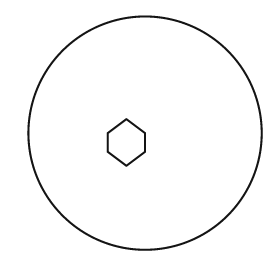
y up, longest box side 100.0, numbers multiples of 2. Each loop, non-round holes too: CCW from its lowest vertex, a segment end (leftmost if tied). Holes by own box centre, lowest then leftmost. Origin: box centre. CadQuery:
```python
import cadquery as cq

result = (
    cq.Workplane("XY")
    .moveTo(0.0, 0.0)
    .circle(50.0)
    .moveTo(-8.0, -14.0)
    .lineTo(0.0, -8.0)
    .lineTo(0.0, 0.0)
    .lineTo(-8.0, 6.0)
    .lineTo(-16.0, 0.0)
    .lineTo(-16.0, -8.0)
    .close()
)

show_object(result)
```